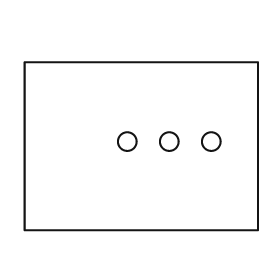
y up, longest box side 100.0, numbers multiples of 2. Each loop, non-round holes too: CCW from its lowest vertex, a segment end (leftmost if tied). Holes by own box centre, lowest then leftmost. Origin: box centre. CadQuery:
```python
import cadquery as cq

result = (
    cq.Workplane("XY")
    .moveTo(-50.0, -36.0)
    .lineTo(50.0, -36.0)
    .lineTo(50.0, 36.0)
    .lineTo(-50.0, 36.0)
    .close()
    .moveTo(-6.0, 2.0)
    .circle(4.0)
    .moveTo(12.0, 2.0)
    .circle(4.0)
    .moveTo(30.0, 2.0)
    .circle(4.0)
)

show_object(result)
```